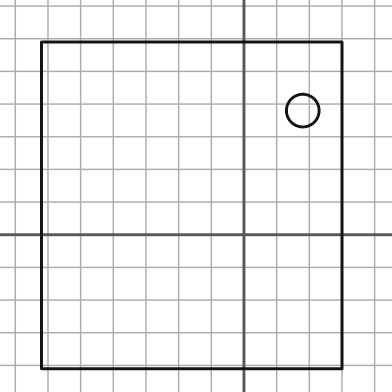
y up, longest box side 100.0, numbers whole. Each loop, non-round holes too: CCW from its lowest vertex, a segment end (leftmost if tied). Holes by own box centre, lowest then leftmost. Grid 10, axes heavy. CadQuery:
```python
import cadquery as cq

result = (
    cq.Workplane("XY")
    .moveTo(-62.0, -41.0)
    .lineTo(30.0, -41.0)
    .lineTo(30.0, 59.0)
    .lineTo(-62.0, 59.0)
    .close()
    .moveTo(18.0, 38.0)
    .circle(5.0)
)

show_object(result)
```